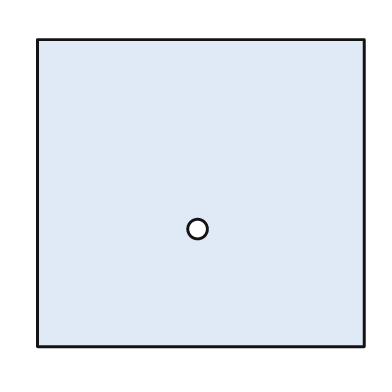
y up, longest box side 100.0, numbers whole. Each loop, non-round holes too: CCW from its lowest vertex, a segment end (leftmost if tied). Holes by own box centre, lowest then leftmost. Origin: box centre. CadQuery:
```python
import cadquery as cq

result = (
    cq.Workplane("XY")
    .moveTo(-50.0, -47.0)
    .lineTo(50.0, -47.0)
    .lineTo(50.0, 47.0)
    .lineTo(-50.0, 47.0)
    .close()
    .moveTo(-1.0, -11.0)
    .circle(3.0)
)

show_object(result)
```